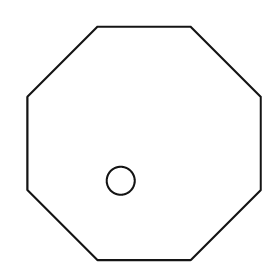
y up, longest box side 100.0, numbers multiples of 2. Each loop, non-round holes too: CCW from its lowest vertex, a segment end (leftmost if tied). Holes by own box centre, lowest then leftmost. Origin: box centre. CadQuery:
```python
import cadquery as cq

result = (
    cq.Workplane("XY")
    .moveTo(-20.0, -50.0)
    .lineTo(20.0, -50.0)
    .lineTo(50.0, -20.0)
    .lineTo(50.0, 20.0)
    .lineTo(20.0, 50.0)
    .lineTo(-20.0, 50.0)
    .lineTo(-50.0, 20.0)
    .lineTo(-50.0, -20.0)
    .close()
    .moveTo(-10.0, -16.0)
    .circle(6.0)
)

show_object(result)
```